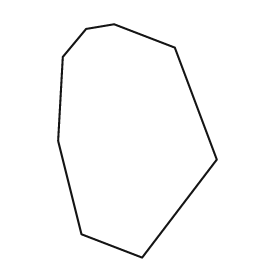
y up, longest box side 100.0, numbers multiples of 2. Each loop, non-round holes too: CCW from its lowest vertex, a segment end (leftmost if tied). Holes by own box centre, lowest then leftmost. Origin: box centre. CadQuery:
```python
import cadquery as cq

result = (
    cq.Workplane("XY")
    .moveTo(2.0, -50.0)
    .lineTo(34.0, -8.0)
    .lineTo(16.0, 40.0)
    .lineTo(-10.0, 50.0)
    .lineTo(-22.0, 48.0)
    .lineTo(-32.0, 36.0)
    .lineTo(-34.0, 0.0)
    .lineTo(-24.0, -40.0)
    .close()
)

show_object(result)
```